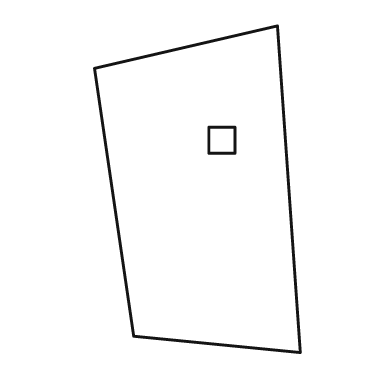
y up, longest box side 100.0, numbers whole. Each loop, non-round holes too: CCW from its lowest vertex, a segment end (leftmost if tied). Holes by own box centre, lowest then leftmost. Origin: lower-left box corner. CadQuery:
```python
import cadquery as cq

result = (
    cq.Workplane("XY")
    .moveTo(63.0, 0.0)
    .lineTo(56.0, 100.0)
    .lineTo(0.0, 87.0)
    .lineTo(12.0, 5.0)
    .close()
    .moveTo(35.0, 61.0)
    .lineTo(43.0, 61.0)
    .lineTo(43.0, 69.0)
    .lineTo(35.0, 69.0)
    .close()
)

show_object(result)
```